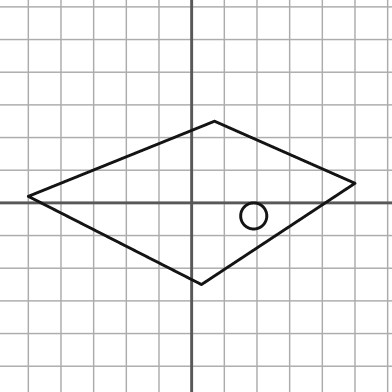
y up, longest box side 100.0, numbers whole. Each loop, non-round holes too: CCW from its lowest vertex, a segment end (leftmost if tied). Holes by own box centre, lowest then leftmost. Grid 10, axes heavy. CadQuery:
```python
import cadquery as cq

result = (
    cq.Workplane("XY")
    .moveTo(3.0, -25.0)
    .lineTo(50.0, 6.0)
    .lineTo(7.0, 25.0)
    .lineTo(-50.0, 2.0)
    .close()
    .moveTo(19.0, -4.0)
    .circle(4.0)
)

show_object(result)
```